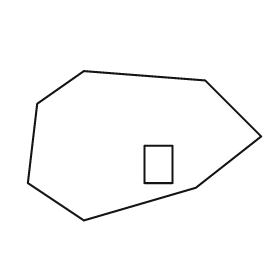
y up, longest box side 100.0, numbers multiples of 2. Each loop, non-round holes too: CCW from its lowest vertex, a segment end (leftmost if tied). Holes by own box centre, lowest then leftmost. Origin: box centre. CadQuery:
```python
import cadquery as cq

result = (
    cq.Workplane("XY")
    .moveTo(-26.0, -32.0)
    .lineTo(22.0, -18.0)
    .lineTo(50.0, 4.0)
    .lineTo(26.0, 28.0)
    .lineTo(-26.0, 32.0)
    .lineTo(-46.0, 18.0)
    .lineTo(-50.0, -16.0)
    .close()
    .moveTo(0.0, -16.0)
    .lineTo(12.0, -16.0)
    .lineTo(12.0, 0.0)
    .lineTo(0.0, 0.0)
    .close()
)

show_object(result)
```